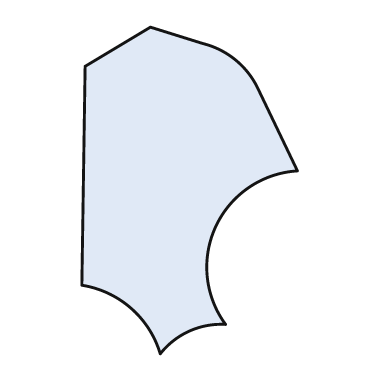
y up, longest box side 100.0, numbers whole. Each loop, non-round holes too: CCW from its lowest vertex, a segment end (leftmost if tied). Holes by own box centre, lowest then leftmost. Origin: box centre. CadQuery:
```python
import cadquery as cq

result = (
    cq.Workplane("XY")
    .moveTo(-9.0, -50.0)
    .threePointArc((0.0, -43.0), (11.0, -41.0))
    .threePointArc((8.0, -11.0), (33.0, 6.0))
    .lineTo(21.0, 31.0)
    .threePointArc((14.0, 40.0), (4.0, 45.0))
    .lineTo(-12.0, 50.0)
    .lineTo(-32.0, 38.0)
    .lineTo(-33.0, -29.0)
    .threePointArc((-18.0, -36.0), (-9.0, -50.0))
    .close()
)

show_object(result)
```